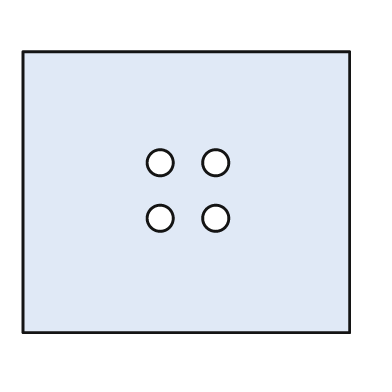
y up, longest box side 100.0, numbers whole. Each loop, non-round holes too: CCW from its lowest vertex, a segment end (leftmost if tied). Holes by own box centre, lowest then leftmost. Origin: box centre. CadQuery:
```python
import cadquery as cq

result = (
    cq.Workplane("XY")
    .moveTo(-50.0, -43.0)
    .lineTo(50.0, -43.0)
    .lineTo(50.0, 43.0)
    .lineTo(-50.0, 43.0)
    .close()
    .moveTo(-8.0, -8.0)
    .circle(4.0)
    .moveTo(9.0, -8.0)
    .circle(4.0)
    .moveTo(-8.0, 9.0)
    .circle(4.0)
    .moveTo(9.0, 9.0)
    .circle(4.0)
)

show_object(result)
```